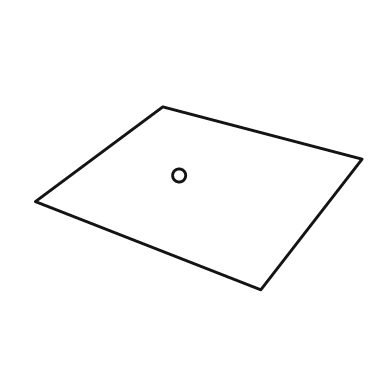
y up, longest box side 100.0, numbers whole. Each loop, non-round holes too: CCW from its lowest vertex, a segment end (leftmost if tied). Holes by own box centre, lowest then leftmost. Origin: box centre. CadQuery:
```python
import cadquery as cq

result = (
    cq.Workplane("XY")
    .moveTo(19.0, -28.0)
    .lineTo(50.0, 12.0)
    .lineTo(-11.0, 28.0)
    .lineTo(-50.0, -1.0)
    .close()
    .moveTo(-6.0, 7.0)
    .circle(2.0)
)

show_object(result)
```